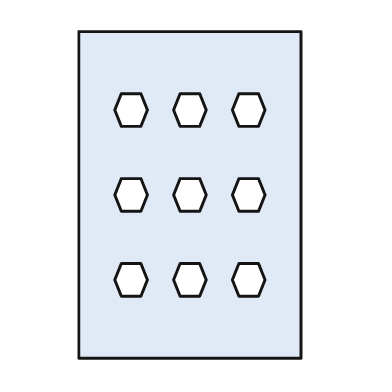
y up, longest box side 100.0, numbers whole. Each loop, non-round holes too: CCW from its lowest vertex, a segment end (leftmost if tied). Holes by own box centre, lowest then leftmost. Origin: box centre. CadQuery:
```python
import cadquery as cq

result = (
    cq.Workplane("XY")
    .moveTo(-34.0, -50.0)
    .lineTo(34.0, -50.0)
    .lineTo(34.0, 50.0)
    .lineTo(-34.0, 50.0)
    .close()
    .moveTo(-21.0, -31.0)
    .lineTo(-15.0, -31.0)
    .lineTo(-13.0, -26.0)
    .lineTo(-15.0, -21.0)
    .lineTo(-21.0, -21.0)
    .lineTo(-23.0, -26.0)
    .close()
    .moveTo(-3.0, -31.0)
    .lineTo(3.0, -31.0)
    .lineTo(5.0, -26.0)
    .lineTo(3.0, -21.0)
    .lineTo(-3.0, -21.0)
    .lineTo(-5.0, -26.0)
    .close()
    .moveTo(15.0, -31.0)
    .lineTo(21.0, -31.0)
    .lineTo(23.0, -26.0)
    .lineTo(21.0, -21.0)
    .lineTo(15.0, -21.0)
    .lineTo(13.0, -26.0)
    .close()
    .moveTo(-21.0, -5.0)
    .lineTo(-15.0, -5.0)
    .lineTo(-13.0, 0.0)
    .lineTo(-15.0, 5.0)
    .lineTo(-21.0, 5.0)
    .lineTo(-23.0, 0.0)
    .close()
    .moveTo(-3.0, -5.0)
    .lineTo(3.0, -5.0)
    .lineTo(5.0, 0.0)
    .lineTo(3.0, 5.0)
    .lineTo(-3.0, 5.0)
    .lineTo(-5.0, 0.0)
    .close()
    .moveTo(15.0, -5.0)
    .lineTo(21.0, -5.0)
    .lineTo(23.0, 0.0)
    .lineTo(21.0, 5.0)
    .lineTo(15.0, 5.0)
    .lineTo(13.0, 0.0)
    .close()
    .moveTo(-21.0, 21.0)
    .lineTo(-15.0, 21.0)
    .lineTo(-13.0, 26.0)
    .lineTo(-15.0, 31.0)
    .lineTo(-21.0, 31.0)
    .lineTo(-23.0, 26.0)
    .close()
    .moveTo(-3.0, 21.0)
    .lineTo(3.0, 21.0)
    .lineTo(5.0, 26.0)
    .lineTo(3.0, 31.0)
    .lineTo(-3.0, 31.0)
    .lineTo(-5.0, 26.0)
    .close()
    .moveTo(15.0, 21.0)
    .lineTo(21.0, 21.0)
    .lineTo(23.0, 26.0)
    .lineTo(21.0, 31.0)
    .lineTo(15.0, 31.0)
    .lineTo(13.0, 26.0)
    .close()
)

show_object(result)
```